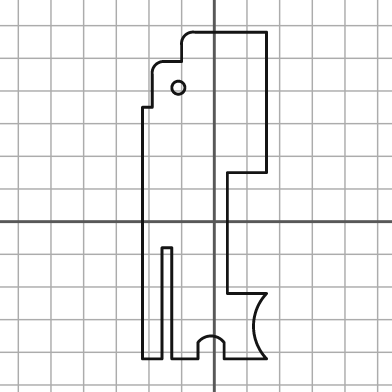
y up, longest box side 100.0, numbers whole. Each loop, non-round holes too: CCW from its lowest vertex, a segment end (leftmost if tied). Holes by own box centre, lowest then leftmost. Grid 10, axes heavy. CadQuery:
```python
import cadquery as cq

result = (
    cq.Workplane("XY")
    .moveTo(-22.0, -42.0)
    .lineTo(-16.0, -42.0)
    .lineTo(-16.0, -8.0)
    .lineTo(-13.0, -8.0)
    .lineTo(-13.0, -42.0)
    .lineTo(-5.0, -42.0)
    .lineTo(-5.0, -37.0)
    .threePointArc((-1.0, -35.0), (3.0, -37.0))
    .lineTo(3.0, -42.0)
    .lineTo(16.0, -42.0)
    .threePointArc((12.0, -32.0), (16.0, -22.0))
    .lineTo(4.0, -22.0)
    .lineTo(4.0, 15.0)
    .lineTo(16.0, 15.0)
    .lineTo(16.0, 58.0)
    .lineTo(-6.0, 58.0)
    .threePointArc((-9.0, 57.0), (-10.0, 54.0))
    .lineTo(-10.0, 49.0)
    .lineTo(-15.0, 49.0)
    .threePointArc((-18.0, 48.0), (-19.0, 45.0))
    .lineTo(-19.0, 35.0)
    .lineTo(-22.0, 35.0)
    .close()
    .moveTo(-11.0, 41.0)
    .circle(2.0)
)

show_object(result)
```